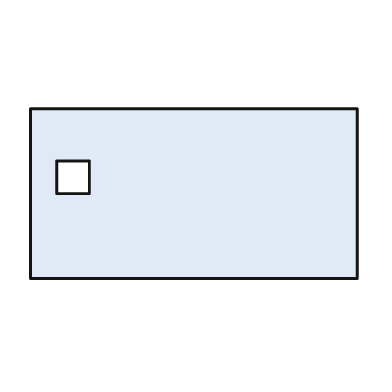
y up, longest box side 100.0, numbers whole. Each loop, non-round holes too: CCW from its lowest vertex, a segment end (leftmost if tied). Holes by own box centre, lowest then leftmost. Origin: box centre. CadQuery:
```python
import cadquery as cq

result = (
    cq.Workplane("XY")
    .moveTo(-50.0, -26.0)
    .lineTo(50.0, -26.0)
    .lineTo(50.0, 26.0)
    .lineTo(-50.0, 26.0)
    .close()
    .moveTo(-42.0, 0.0)
    .lineTo(-32.0, 0.0)
    .lineTo(-32.0, 10.0)
    .lineTo(-42.0, 10.0)
    .close()
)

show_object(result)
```